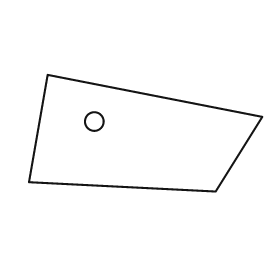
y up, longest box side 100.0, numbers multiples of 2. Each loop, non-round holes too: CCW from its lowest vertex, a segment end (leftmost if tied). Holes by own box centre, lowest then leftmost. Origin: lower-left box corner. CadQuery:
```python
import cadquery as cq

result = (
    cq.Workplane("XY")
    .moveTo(80.0, 0.0)
    .lineTo(100.0, 32.0)
    .lineTo(8.0, 50.0)
    .lineTo(0.0, 4.0)
    .close()
    .moveTo(28.0, 30.0)
    .circle(4.0)
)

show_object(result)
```